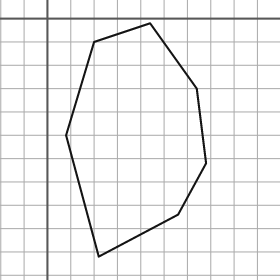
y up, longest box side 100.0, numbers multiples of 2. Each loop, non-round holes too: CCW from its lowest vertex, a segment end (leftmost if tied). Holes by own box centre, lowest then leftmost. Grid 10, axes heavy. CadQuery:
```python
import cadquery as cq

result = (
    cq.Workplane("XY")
    .moveTo(22.0, -102.0)
    .lineTo(56.0, -84.0)
    .lineTo(68.0, -62.0)
    .lineTo(64.0, -30.0)
    .lineTo(44.0, -2.0)
    .lineTo(20.0, -10.0)
    .lineTo(8.0, -50.0)
    .close()
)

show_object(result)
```